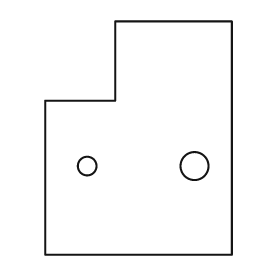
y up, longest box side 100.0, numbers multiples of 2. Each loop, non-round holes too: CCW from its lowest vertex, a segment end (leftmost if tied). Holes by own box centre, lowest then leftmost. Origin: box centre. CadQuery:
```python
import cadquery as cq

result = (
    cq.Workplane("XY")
    .moveTo(-40.0, -50.0)
    .lineTo(40.0, -50.0)
    .lineTo(40.0, 50.0)
    .lineTo(-10.0, 50.0)
    .lineTo(-10.0, 16.0)
    .lineTo(-40.0, 16.0)
    .close()
    .moveTo(-22.0, -12.0)
    .circle(4.0)
    .moveTo(24.0, -12.0)
    .circle(6.0)
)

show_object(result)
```